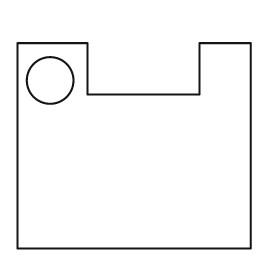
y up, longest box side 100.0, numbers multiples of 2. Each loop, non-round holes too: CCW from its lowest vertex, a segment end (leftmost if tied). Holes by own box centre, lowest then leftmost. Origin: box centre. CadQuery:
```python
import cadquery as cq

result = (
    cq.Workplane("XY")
    .moveTo(-50.0, -44.0)
    .lineTo(50.0, -44.0)
    .lineTo(50.0, 44.0)
    .lineTo(28.0, 44.0)
    .lineTo(28.0, 22.0)
    .lineTo(-20.0, 22.0)
    .lineTo(-20.0, 44.0)
    .lineTo(-50.0, 44.0)
    .close()
    .moveTo(-36.0, 28.0)
    .circle(10.0)
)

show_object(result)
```